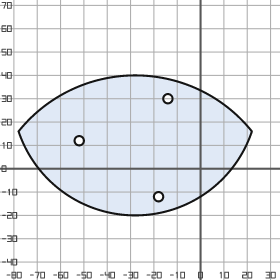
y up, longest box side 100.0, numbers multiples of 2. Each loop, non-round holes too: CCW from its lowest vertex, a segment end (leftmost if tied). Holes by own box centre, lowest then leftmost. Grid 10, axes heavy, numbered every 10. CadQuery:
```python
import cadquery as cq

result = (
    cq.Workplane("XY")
    .moveTo(-78.0, 16.0)
    .threePointArc((-28.0, -20.0), (22.0, 16.0))
    .threePointArc((-28.0, 40.0), (-78.0, 16.0))
    .close()
    .moveTo(-18.0, -12.0)
    .circle(2.0)
    .moveTo(-52.0, 12.0)
    .circle(2.0)
    .moveTo(-14.0, 30.0)
    .circle(2.0)
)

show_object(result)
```